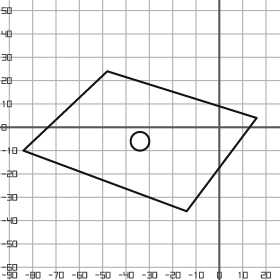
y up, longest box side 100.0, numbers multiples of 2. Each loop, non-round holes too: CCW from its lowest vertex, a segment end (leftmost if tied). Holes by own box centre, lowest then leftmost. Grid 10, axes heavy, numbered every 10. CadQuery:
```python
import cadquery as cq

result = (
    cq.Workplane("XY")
    .moveTo(-14.0, -36.0)
    .lineTo(16.0, 4.0)
    .lineTo(-48.0, 24.0)
    .lineTo(-84.0, -10.0)
    .close()
    .moveTo(-34.0, -6.0)
    .circle(4.0)
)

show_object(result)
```